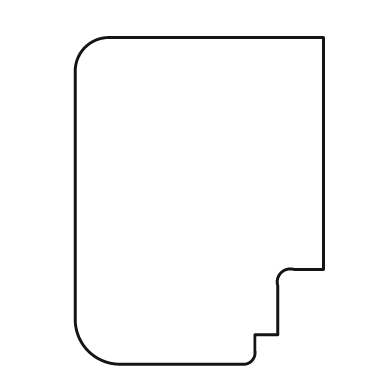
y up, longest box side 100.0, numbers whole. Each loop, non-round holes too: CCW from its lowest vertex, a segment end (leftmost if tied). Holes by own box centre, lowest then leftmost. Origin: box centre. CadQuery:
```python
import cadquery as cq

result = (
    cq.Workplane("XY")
    .moveTo(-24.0, -50.0)
    .lineTo(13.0, -50.0)
    .threePointArc((16.0, -49.0), (17.0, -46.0))
    .lineTo(17.0, -41.0)
    .lineTo(24.0, -41.0)
    .lineTo(24.0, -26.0)
    .threePointArc((25.0, -22.0), (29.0, -21.0))
    .lineTo(38.0, -21.0)
    .lineTo(38.0, 50.0)
    .lineTo(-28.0, 50.0)
    .threePointArc((-35.0, 47.0), (-38.0, 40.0))
    .lineTo(-38.0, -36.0)
    .threePointArc((-34.0, -46.0), (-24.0, -50.0))
    .close()
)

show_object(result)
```